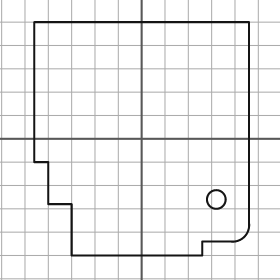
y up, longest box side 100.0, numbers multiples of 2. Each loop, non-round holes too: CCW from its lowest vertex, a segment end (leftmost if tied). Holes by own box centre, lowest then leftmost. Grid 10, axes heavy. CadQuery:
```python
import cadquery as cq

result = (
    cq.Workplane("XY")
    .moveTo(-30.0, -50.0)
    .lineTo(26.0, -50.0)
    .lineTo(26.0, -44.0)
    .lineTo(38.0, -44.0)
    .threePointArc((44.0, -42.0), (46.0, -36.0))
    .lineTo(46.0, 50.0)
    .lineTo(-46.0, 50.0)
    .lineTo(-46.0, -10.0)
    .lineTo(-40.0, -10.0)
    .lineTo(-40.0, -28.0)
    .lineTo(-30.0, -28.0)
    .close()
    .moveTo(32.0, -26.0)
    .circle(4.0)
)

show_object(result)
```